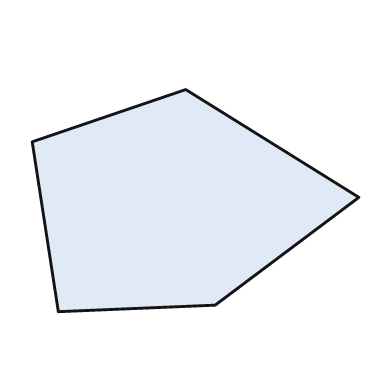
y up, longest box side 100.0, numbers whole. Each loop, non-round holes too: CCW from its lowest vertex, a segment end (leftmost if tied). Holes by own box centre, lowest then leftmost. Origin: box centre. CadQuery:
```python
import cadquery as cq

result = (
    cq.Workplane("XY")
    .moveTo(-42.0, -34.0)
    .lineTo(6.0, -32.0)
    .lineTo(50.0, 1.0)
    .lineTo(-3.0, 34.0)
    .lineTo(-50.0, 18.0)
    .close()
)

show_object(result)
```